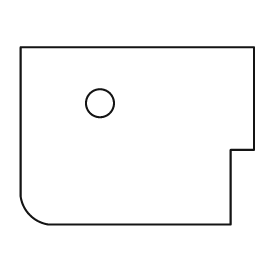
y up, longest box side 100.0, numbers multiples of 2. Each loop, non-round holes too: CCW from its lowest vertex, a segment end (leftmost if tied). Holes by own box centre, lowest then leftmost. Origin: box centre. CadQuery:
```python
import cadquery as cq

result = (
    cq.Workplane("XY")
    .moveTo(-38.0, -38.0)
    .lineTo(40.0, -38.0)
    .lineTo(40.0, -6.0)
    .lineTo(50.0, -6.0)
    .lineTo(50.0, 38.0)
    .lineTo(-50.0, 38.0)
    .lineTo(-50.0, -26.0)
    .threePointArc((-46.0, -34.0), (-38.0, -38.0))
    .close()
    .moveTo(-16.0, 14.0)
    .circle(6.0)
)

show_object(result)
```